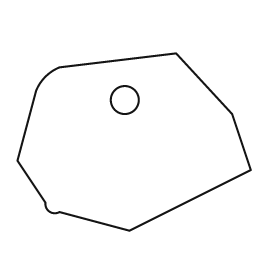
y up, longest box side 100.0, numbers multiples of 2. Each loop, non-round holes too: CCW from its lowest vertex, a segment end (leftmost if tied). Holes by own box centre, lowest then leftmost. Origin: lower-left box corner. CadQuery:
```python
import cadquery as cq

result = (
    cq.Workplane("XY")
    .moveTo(48.0, 0.0)
    .lineTo(100.0, 26.0)
    .lineTo(92.0, 50.0)
    .lineTo(68.0, 76.0)
    .lineTo(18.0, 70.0)
    .threePointArc((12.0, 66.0), (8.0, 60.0))
    .lineTo(0.0, 30.0)
    .lineTo(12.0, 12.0)
    .threePointArc((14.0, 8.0), (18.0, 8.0))
    .close()
    .moveTo(46.0, 56.0)
    .circle(6.0)
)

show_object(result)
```